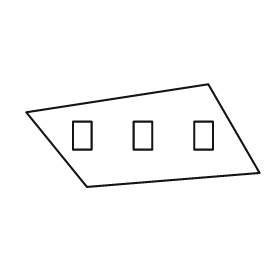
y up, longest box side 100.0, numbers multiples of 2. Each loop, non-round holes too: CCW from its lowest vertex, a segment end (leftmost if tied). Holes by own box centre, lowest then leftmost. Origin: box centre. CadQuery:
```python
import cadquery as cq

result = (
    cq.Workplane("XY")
    .moveTo(-24.0, -22.0)
    .lineTo(50.0, -16.0)
    .lineTo(28.0, 22.0)
    .lineTo(-50.0, 10.0)
    .close()
    .moveTo(-30.0, -6.0)
    .lineTo(-22.0, -6.0)
    .lineTo(-22.0, 6.0)
    .lineTo(-30.0, 6.0)
    .close()
    .moveTo(-4.0, -6.0)
    .lineTo(4.0, -6.0)
    .lineTo(4.0, 6.0)
    .lineTo(-4.0, 6.0)
    .close()
    .moveTo(22.0, -6.0)
    .lineTo(30.0, -6.0)
    .lineTo(30.0, 6.0)
    .lineTo(22.0, 6.0)
    .close()
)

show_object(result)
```